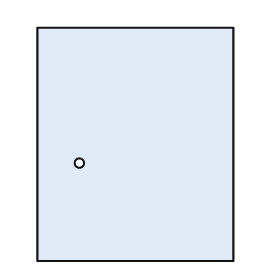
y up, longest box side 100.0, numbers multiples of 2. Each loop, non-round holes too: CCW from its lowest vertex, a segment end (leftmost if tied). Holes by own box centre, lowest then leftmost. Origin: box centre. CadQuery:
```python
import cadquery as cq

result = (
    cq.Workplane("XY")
    .moveTo(-42.0, -50.0)
    .lineTo(42.0, -50.0)
    .lineTo(42.0, 50.0)
    .lineTo(-42.0, 50.0)
    .close()
    .moveTo(-24.0, -8.0)
    .circle(2.0)
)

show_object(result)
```